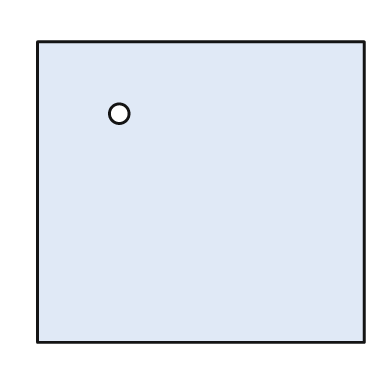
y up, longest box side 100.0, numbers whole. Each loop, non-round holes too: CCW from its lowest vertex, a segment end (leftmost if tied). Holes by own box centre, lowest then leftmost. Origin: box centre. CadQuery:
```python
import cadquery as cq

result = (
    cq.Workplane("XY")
    .moveTo(-50.0, -46.0)
    .lineTo(50.0, -46.0)
    .lineTo(50.0, 46.0)
    .lineTo(-50.0, 46.0)
    .close()
    .moveTo(-25.0, 24.0)
    .circle(3.0)
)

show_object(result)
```